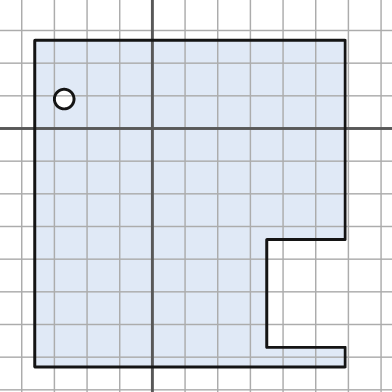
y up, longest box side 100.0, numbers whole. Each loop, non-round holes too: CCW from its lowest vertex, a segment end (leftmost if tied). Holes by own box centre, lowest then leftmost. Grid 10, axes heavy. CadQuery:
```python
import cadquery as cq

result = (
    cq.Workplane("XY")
    .moveTo(-36.0, -73.0)
    .lineTo(59.0, -73.0)
    .lineTo(59.0, -67.0)
    .lineTo(35.0, -67.0)
    .lineTo(35.0, -34.0)
    .lineTo(59.0, -34.0)
    .lineTo(59.0, 27.0)
    .lineTo(-36.0, 27.0)
    .close()
    .moveTo(-27.0, 9.0)
    .circle(3.0)
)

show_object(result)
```